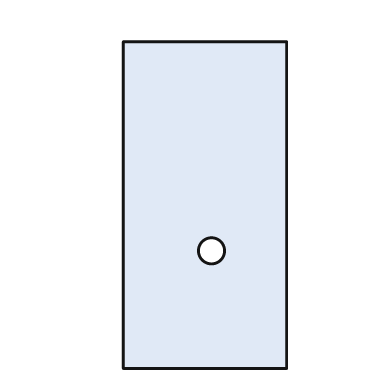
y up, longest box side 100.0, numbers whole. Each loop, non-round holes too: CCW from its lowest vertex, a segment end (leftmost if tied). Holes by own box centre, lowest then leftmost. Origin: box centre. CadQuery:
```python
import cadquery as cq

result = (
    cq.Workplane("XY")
    .moveTo(-25.0, -50.0)
    .lineTo(25.0, -50.0)
    .lineTo(25.0, 50.0)
    .lineTo(-25.0, 50.0)
    .close()
    .moveTo(2.0, -14.0)
    .circle(4.0)
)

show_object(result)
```